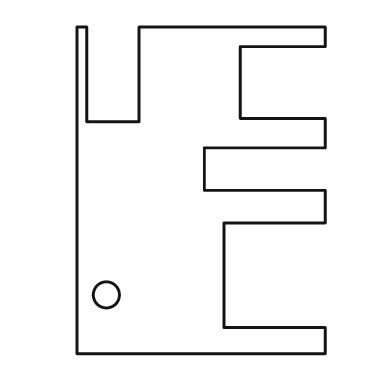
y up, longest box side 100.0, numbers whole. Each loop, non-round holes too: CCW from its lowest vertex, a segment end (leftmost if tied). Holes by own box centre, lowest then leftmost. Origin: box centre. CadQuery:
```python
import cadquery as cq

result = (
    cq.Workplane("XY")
    .moveTo(-38.0, -50.0)
    .lineTo(38.0, -50.0)
    .lineTo(38.0, -42.0)
    .lineTo(7.0, -42.0)
    .lineTo(7.0, -10.0)
    .lineTo(38.0, -10.0)
    .lineTo(38.0, 0.0)
    .lineTo(1.0, 0.0)
    .lineTo(1.0, 13.0)
    .lineTo(38.0, 13.0)
    .lineTo(38.0, 22.0)
    .lineTo(12.0, 22.0)
    .lineTo(12.0, 44.0)
    .lineTo(38.0, 44.0)
    .lineTo(38.0, 50.0)
    .lineTo(-19.0, 50.0)
    .lineTo(-19.0, 21.0)
    .lineTo(-35.0, 21.0)
    .lineTo(-35.0, 50.0)
    .lineTo(-38.0, 50.0)
    .close()
    .moveTo(-29.0, -32.0)
    .circle(4.0)
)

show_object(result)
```